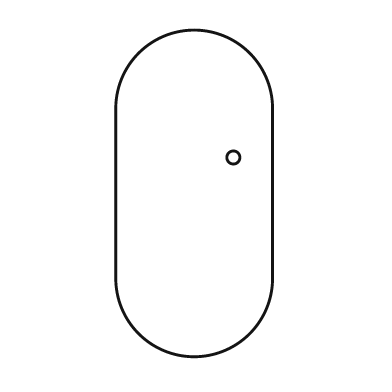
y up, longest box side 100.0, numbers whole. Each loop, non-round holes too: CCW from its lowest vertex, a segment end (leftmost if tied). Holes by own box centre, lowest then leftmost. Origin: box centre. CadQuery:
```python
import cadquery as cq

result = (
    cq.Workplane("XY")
    .moveTo(-24.0, -26.0)
    .threePointArc((0.0, -50.0), (24.0, -26.0))
    .lineTo(24.0, 26.0)
    .threePointArc((0.0, 50.0), (-24.0, 26.0))
    .close()
    .moveTo(12.0, 11.0)
    .circle(2.0)
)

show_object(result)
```